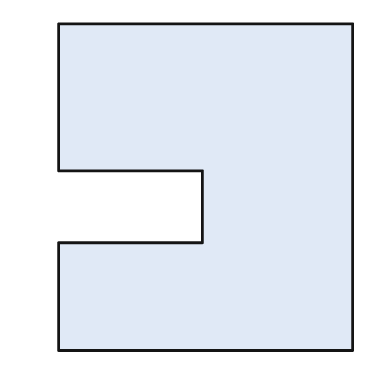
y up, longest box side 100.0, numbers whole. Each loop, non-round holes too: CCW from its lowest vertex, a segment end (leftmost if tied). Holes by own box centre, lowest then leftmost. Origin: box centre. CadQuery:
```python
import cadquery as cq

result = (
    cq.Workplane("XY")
    .moveTo(-45.0, -50.0)
    .lineTo(45.0, -50.0)
    .lineTo(45.0, 50.0)
    .lineTo(-45.0, 50.0)
    .lineTo(-45.0, 5.0)
    .lineTo(-1.0, 5.0)
    .lineTo(-1.0, -17.0)
    .lineTo(-45.0, -17.0)
    .close()
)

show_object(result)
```